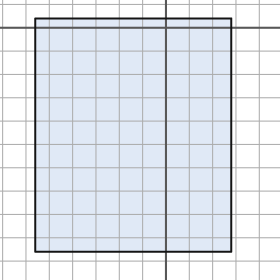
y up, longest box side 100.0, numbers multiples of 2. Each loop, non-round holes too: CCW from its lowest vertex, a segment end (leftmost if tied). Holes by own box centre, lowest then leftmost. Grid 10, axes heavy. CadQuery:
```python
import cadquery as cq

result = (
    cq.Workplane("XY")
    .moveTo(-56.0, -96.0)
    .lineTo(28.0, -96.0)
    .lineTo(28.0, 4.0)
    .lineTo(-56.0, 4.0)
    .close()
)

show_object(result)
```